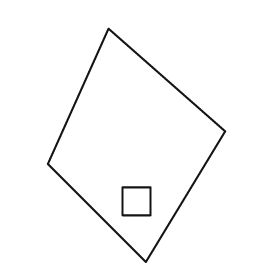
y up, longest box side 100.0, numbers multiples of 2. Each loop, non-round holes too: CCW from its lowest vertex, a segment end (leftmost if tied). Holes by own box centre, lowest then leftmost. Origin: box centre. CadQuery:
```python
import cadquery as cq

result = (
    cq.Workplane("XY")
    .moveTo(4.0, -50.0)
    .lineTo(38.0, 6.0)
    .lineTo(-12.0, 50.0)
    .lineTo(-38.0, -8.0)
    .close()
    .moveTo(-6.0, -30.0)
    .lineTo(6.0, -30.0)
    .lineTo(6.0, -18.0)
    .lineTo(-6.0, -18.0)
    .close()
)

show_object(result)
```